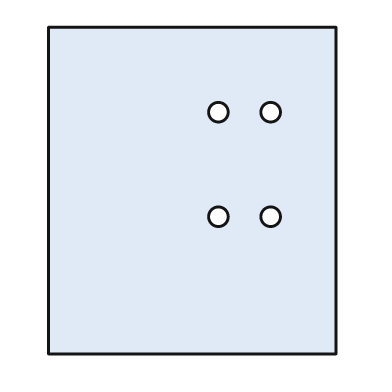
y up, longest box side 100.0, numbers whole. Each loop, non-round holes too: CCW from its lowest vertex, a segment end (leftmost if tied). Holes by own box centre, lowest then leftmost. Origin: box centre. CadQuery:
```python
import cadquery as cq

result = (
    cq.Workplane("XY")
    .moveTo(-44.0, -50.0)
    .lineTo(44.0, -50.0)
    .lineTo(44.0, 50.0)
    .lineTo(-44.0, 50.0)
    .close()
    .moveTo(8.0, -8.0)
    .circle(3.0)
    .moveTo(24.0, -8.0)
    .circle(3.0)
    .moveTo(8.0, 24.0)
    .circle(3.0)
    .moveTo(24.0, 24.0)
    .circle(3.0)
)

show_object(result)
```